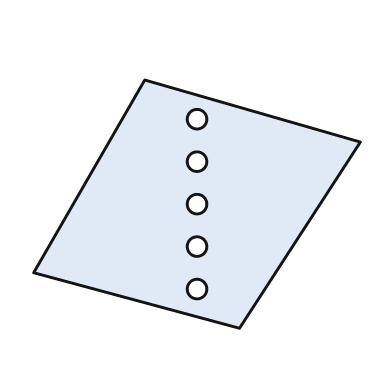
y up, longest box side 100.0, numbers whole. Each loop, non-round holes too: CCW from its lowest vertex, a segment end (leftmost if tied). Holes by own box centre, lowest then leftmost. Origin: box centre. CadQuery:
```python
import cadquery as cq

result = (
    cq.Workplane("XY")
    .moveTo(13.0, -38.0)
    .lineTo(50.0, 19.0)
    .lineTo(-16.0, 38.0)
    .lineTo(-50.0, -21.0)
    .close()
    .moveTo(0.0, -26.0)
    .circle(3.0)
    .moveTo(0.0, -13.0)
    .circle(3.0)
    .moveTo(0.0, 0.0)
    .circle(3.0)
    .moveTo(0.0, 13.0)
    .circle(3.0)
    .moveTo(0.0, 26.0)
    .circle(3.0)
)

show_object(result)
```